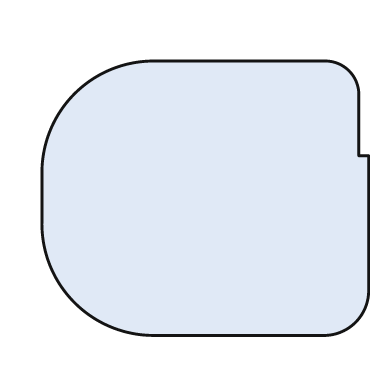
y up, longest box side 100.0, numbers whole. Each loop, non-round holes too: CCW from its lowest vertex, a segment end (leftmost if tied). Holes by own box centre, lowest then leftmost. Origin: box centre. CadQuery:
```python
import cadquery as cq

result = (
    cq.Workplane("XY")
    .moveTo(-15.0, -42.0)
    .lineTo(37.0, -42.0)
    .threePointArc((46.0, -38.0), (50.0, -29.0))
    .lineTo(50.0, 13.0)
    .lineTo(47.0, 13.0)
    .lineTo(47.0, 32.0)
    .threePointArc((44.0, 39.0), (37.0, 42.0))
    .lineTo(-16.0, 42.0)
    .threePointArc((-40.0, 32.0), (-50.0, 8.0))
    .lineTo(-50.0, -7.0)
    .threePointArc((-40.0, -32.0), (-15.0, -42.0))
    .close()
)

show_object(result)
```